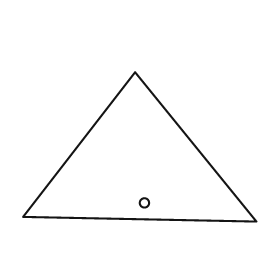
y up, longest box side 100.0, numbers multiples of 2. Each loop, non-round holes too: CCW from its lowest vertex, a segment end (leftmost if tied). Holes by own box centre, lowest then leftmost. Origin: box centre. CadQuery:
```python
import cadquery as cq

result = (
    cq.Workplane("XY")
    .moveTo(50.0, -32.0)
    .lineTo(-2.0, 32.0)
    .lineTo(-50.0, -30.0)
    .close()
    .moveTo(2.0, -24.0)
    .circle(2.0)
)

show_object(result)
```